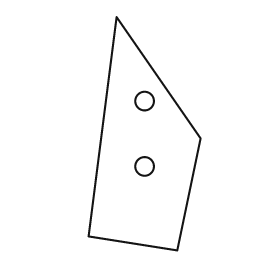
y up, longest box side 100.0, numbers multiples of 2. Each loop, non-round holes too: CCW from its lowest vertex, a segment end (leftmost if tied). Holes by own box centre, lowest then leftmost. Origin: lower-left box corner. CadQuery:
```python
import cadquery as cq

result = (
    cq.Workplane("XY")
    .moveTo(38.0, 0.0)
    .lineTo(48.0, 48.0)
    .lineTo(12.0, 100.0)
    .lineTo(0.0, 6.0)
    .close()
    .moveTo(24.0, 36.0)
    .circle(4.0)
    .moveTo(24.0, 64.0)
    .circle(4.0)
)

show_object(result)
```